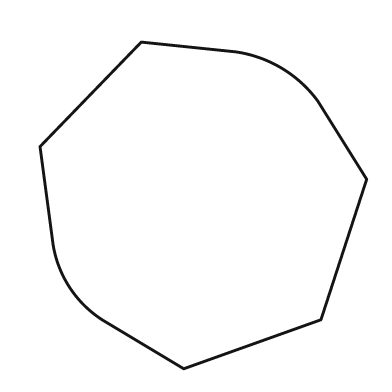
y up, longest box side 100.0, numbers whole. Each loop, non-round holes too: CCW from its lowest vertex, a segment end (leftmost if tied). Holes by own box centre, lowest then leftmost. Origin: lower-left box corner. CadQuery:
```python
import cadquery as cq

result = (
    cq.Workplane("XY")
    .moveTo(44.0, 0.0)
    .lineTo(86.0, 15.0)
    .lineTo(100.0, 58.0)
    .lineTo(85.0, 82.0)
    .threePointArc((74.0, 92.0), (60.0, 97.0))
    .lineTo(31.0, 100.0)
    .lineTo(0.0, 68.0)
    .lineTo(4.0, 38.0)
    .threePointArc((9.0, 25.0), (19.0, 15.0))
    .close()
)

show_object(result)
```